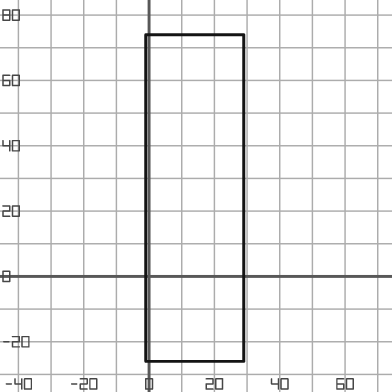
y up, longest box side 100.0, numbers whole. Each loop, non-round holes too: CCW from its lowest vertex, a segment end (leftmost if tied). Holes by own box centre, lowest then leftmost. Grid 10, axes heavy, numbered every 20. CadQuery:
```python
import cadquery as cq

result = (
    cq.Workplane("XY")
    .moveTo(-1.0, -26.0)
    .lineTo(29.0, -26.0)
    .lineTo(29.0, 74.0)
    .lineTo(-1.0, 74.0)
    .close()
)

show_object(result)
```